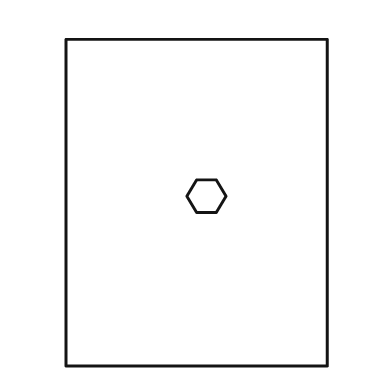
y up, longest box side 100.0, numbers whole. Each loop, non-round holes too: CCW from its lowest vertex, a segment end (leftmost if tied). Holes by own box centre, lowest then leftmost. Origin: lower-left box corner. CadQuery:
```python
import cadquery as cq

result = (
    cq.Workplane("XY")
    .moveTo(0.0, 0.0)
    .lineTo(80.0, 0.0)
    .lineTo(80.0, 100.0)
    .lineTo(0.0, 100.0)
    .close()
    .moveTo(40.0, 47.0)
    .lineTo(46.0, 47.0)
    .lineTo(49.0, 52.0)
    .lineTo(46.0, 57.0)
    .lineTo(40.0, 57.0)
    .lineTo(37.0, 52.0)
    .close()
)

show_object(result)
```